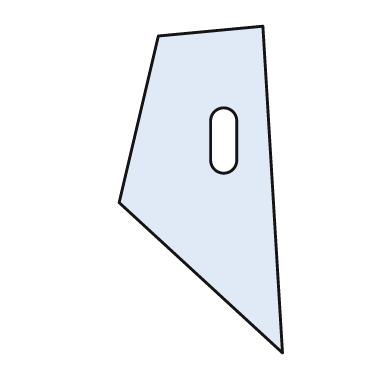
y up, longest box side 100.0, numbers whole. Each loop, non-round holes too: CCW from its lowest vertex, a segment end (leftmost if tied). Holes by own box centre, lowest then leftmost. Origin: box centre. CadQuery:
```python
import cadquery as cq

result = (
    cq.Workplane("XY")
    .moveTo(25.0, -50.0)
    .lineTo(19.0, 50.0)
    .lineTo(-13.0, 47.0)
    .lineTo(-25.0, -4.0)
    .close()
    .moveTo(3.0, 9.0)
    .threePointArc((7.0, 5.0), (11.0, 9.0))
    .lineTo(11.0, 21.0)
    .threePointArc((7.0, 25.0), (3.0, 21.0))
    .close()
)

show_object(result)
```